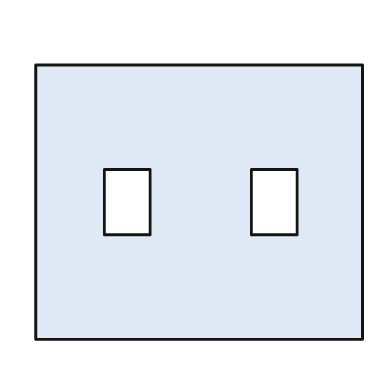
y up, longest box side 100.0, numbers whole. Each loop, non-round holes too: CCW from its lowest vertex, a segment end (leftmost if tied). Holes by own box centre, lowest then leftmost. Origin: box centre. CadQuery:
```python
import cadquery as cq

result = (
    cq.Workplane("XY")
    .moveTo(-50.0, -42.0)
    .lineTo(50.0, -42.0)
    .lineTo(50.0, 42.0)
    .lineTo(-50.0, 42.0)
    .close()
    .moveTo(-29.0, -10.0)
    .lineTo(-15.0, -10.0)
    .lineTo(-15.0, 10.0)
    .lineTo(-29.0, 10.0)
    .close()
    .moveTo(16.0, -10.0)
    .lineTo(30.0, -10.0)
    .lineTo(30.0, 10.0)
    .lineTo(16.0, 10.0)
    .close()
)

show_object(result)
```